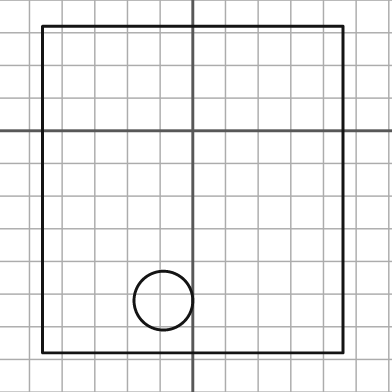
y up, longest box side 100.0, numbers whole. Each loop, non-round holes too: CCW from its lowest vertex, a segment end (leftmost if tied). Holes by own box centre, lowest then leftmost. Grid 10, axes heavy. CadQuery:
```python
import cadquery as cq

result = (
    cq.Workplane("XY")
    .moveTo(-46.0, -68.0)
    .lineTo(46.0, -68.0)
    .lineTo(46.0, 32.0)
    .lineTo(-46.0, 32.0)
    .close()
    .moveTo(-9.0, -52.0)
    .circle(9.0)
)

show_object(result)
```